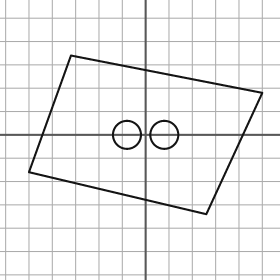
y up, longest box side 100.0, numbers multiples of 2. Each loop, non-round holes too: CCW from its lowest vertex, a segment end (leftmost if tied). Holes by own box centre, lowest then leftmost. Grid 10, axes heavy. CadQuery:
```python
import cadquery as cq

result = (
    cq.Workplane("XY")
    .moveTo(26.0, -34.0)
    .lineTo(50.0, 18.0)
    .lineTo(-32.0, 34.0)
    .lineTo(-50.0, -16.0)
    .close()
    .moveTo(-8.0, 0.0)
    .circle(6.0)
    .moveTo(8.0, 0.0)
    .circle(6.0)
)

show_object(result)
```